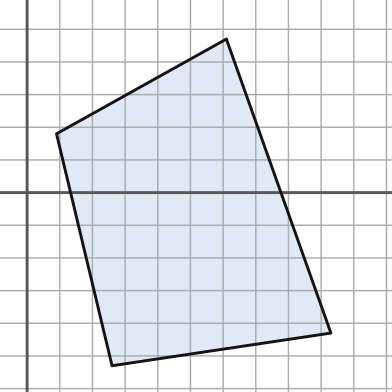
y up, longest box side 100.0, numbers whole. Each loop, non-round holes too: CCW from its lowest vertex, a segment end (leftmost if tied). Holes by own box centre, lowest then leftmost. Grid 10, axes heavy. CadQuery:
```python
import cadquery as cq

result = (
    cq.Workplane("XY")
    .moveTo(26.0, -53.0)
    .lineTo(93.0, -43.0)
    .lineTo(61.0, 47.0)
    .lineTo(9.0, 18.0)
    .close()
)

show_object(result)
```